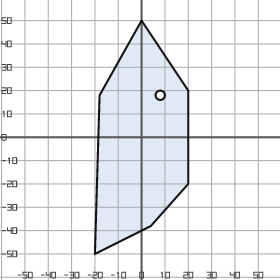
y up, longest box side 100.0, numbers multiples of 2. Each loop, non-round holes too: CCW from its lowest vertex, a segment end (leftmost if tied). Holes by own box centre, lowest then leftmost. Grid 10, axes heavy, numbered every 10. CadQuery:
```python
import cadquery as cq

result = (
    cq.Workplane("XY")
    .moveTo(-20.0, -50.0)
    .lineTo(4.0, -38.0)
    .lineTo(20.0, -20.0)
    .lineTo(20.0, 20.0)
    .lineTo(0.0, 50.0)
    .lineTo(-18.0, 18.0)
    .close()
    .moveTo(8.0, 18.0)
    .circle(2.0)
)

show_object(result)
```